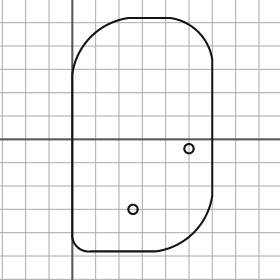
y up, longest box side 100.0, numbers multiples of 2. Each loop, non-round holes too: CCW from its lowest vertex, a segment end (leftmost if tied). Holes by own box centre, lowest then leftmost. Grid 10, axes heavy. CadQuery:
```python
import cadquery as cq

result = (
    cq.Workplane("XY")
    .moveTo(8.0, -48.0)
    .lineTo(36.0, -48.0)
    .threePointArc((52.0, -40.0), (60.0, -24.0))
    .lineTo(60.0, 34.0)
    .threePointArc((54.0, 46.0), (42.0, 52.0))
    .lineTo(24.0, 52.0)
    .threePointArc((8.0, 44.0), (0.0, 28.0))
    .lineTo(0.0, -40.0)
    .threePointArc((2.0, -46.0), (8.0, -48.0))
    .close()
    .moveTo(26.0, -30.0)
    .circle(2.0)
    .moveTo(50.0, -4.0)
    .circle(2.0)
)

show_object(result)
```